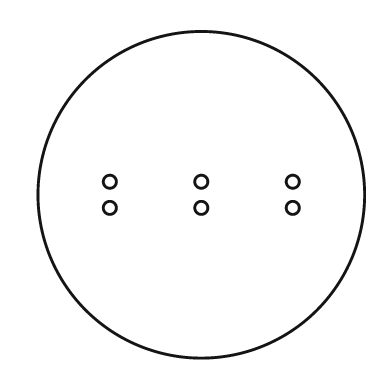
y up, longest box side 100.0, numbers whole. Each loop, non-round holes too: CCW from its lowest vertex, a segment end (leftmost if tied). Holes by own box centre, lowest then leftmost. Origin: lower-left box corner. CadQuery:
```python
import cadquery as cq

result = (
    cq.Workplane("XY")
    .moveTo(50.0, 50.0)
    .circle(50.0)
    .moveTo(22.0, 46.0)
    .circle(2.0)
    .moveTo(50.0, 46.0)
    .circle(2.0)
    .moveTo(78.0, 46.0)
    .circle(2.0)
    .moveTo(22.0, 54.0)
    .circle(2.0)
    .moveTo(50.0, 54.0)
    .circle(2.0)
    .moveTo(78.0, 54.0)
    .circle(2.0)
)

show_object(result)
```